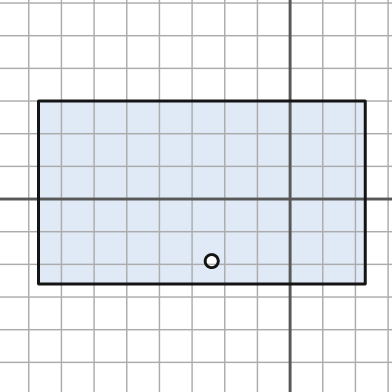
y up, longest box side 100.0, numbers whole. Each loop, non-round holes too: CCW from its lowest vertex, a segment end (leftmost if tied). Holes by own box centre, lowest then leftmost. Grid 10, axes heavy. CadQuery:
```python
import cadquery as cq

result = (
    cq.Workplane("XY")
    .moveTo(-77.0, -26.0)
    .lineTo(23.0, -26.0)
    .lineTo(23.0, 30.0)
    .lineTo(-77.0, 30.0)
    .close()
    .moveTo(-24.0, -19.0)
    .circle(2.0)
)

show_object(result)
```